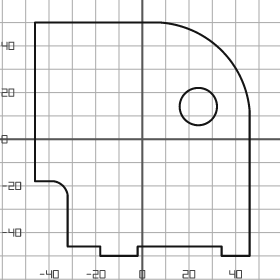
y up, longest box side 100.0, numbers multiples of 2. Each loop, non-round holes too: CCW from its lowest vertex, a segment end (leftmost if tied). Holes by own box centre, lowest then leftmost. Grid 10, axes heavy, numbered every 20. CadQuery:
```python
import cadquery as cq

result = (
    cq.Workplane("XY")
    .moveTo(-18.0, -50.0)
    .lineTo(-2.0, -50.0)
    .lineTo(-2.0, -46.0)
    .lineTo(34.0, -46.0)
    .lineTo(34.0, -50.0)
    .lineTo(46.0, -50.0)
    .lineTo(46.0, 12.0)
    .threePointArc((34.0, 38.0), (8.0, 50.0))
    .lineTo(-46.0, 50.0)
    .lineTo(-46.0, -18.0)
    .lineTo(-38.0, -18.0)
    .threePointArc((-34.0, -20.0), (-32.0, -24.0))
    .lineTo(-32.0, -46.0)
    .lineTo(-18.0, -46.0)
    .close()
    .moveTo(24.0, 14.0)
    .circle(8.0)
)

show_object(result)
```